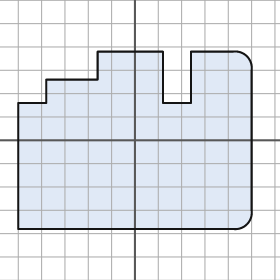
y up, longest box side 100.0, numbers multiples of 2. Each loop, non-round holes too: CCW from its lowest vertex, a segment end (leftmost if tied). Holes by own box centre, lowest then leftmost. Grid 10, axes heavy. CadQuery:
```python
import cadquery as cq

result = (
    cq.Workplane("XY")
    .moveTo(-50.0, -38.0)
    .lineTo(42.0, -38.0)
    .threePointArc((48.0, -36.0), (50.0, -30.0))
    .lineTo(50.0, 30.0)
    .threePointArc((48.0, 36.0), (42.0, 38.0))
    .lineTo(24.0, 38.0)
    .lineTo(24.0, 16.0)
    .lineTo(12.0, 16.0)
    .lineTo(12.0, 38.0)
    .lineTo(-16.0, 38.0)
    .lineTo(-16.0, 26.0)
    .lineTo(-38.0, 26.0)
    .lineTo(-38.0, 16.0)
    .lineTo(-50.0, 16.0)
    .close()
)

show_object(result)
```